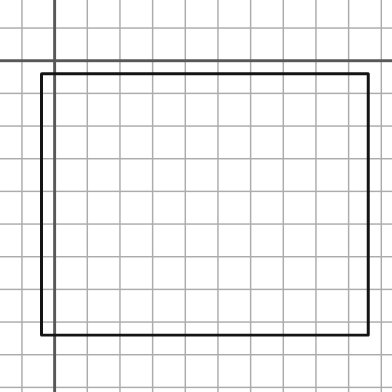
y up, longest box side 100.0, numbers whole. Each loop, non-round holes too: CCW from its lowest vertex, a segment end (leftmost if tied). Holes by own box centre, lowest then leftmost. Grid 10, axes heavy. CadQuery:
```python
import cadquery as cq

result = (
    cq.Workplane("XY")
    .moveTo(-4.0, -84.0)
    .lineTo(96.0, -84.0)
    .lineTo(96.0, -4.0)
    .lineTo(-4.0, -4.0)
    .close()
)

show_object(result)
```